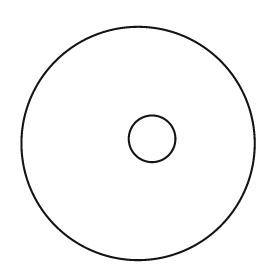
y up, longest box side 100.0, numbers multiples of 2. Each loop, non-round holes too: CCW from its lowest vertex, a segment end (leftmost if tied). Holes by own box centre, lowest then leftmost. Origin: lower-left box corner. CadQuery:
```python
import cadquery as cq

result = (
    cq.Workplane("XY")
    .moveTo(50.0, 50.0)
    .circle(50.0)
    .moveTo(56.0, 52.0)
    .circle(10.0)
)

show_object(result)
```